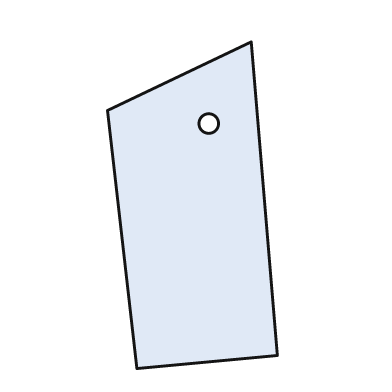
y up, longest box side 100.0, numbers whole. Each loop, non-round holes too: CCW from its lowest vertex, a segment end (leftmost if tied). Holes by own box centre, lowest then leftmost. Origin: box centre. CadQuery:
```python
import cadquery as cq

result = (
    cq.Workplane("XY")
    .moveTo(-17.0, -50.0)
    .lineTo(26.0, -46.0)
    .lineTo(18.0, 50.0)
    .lineTo(-26.0, 29.0)
    .close()
    .moveTo(5.0, 25.0)
    .circle(3.0)
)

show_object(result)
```